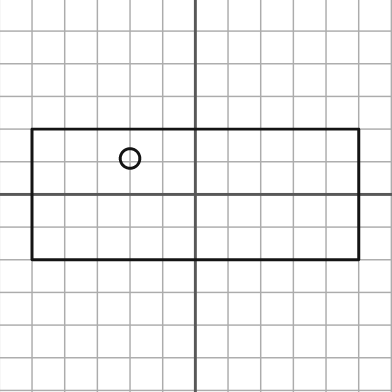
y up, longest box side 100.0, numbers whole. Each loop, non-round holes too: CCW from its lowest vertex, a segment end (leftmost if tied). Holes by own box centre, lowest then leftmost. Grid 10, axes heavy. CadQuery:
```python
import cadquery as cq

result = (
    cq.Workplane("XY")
    .moveTo(-50.0, -20.0)
    .lineTo(50.0, -20.0)
    .lineTo(50.0, 20.0)
    .lineTo(-50.0, 20.0)
    .close()
    .moveTo(-20.0, 11.0)
    .circle(3.0)
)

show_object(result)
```